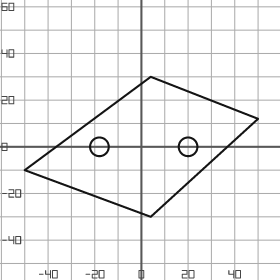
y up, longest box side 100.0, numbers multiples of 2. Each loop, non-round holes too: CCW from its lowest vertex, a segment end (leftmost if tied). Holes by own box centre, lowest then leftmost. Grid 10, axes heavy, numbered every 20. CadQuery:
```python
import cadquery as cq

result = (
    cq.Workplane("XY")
    .moveTo(4.0, -30.0)
    .lineTo(50.0, 12.0)
    .lineTo(4.0, 30.0)
    .lineTo(-50.0, -10.0)
    .close()
    .moveTo(-18.0, 0.0)
    .circle(4.0)
    .moveTo(20.0, 0.0)
    .circle(4.0)
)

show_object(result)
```